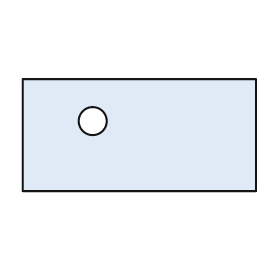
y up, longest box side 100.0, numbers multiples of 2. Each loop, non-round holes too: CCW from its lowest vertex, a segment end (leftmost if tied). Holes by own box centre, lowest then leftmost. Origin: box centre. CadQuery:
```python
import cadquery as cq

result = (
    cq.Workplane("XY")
    .moveTo(-50.0, -24.0)
    .lineTo(50.0, -24.0)
    .lineTo(50.0, 24.0)
    .lineTo(-50.0, 24.0)
    .close()
    .moveTo(-20.0, 6.0)
    .circle(6.0)
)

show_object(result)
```